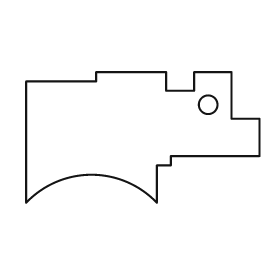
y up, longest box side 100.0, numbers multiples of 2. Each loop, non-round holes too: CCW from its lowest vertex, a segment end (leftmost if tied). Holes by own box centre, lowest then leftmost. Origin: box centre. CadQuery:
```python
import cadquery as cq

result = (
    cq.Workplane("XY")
    .moveTo(-50.0, -28.0)
    .threePointArc((-22.0, -16.0), (6.0, -28.0))
    .lineTo(6.0, -12.0)
    .lineTo(12.0, -12.0)
    .lineTo(12.0, -8.0)
    .lineTo(50.0, -8.0)
    .lineTo(50.0, 8.0)
    .lineTo(38.0, 8.0)
    .lineTo(38.0, 28.0)
    .lineTo(22.0, 28.0)
    .lineTo(22.0, 20.0)
    .lineTo(10.0, 20.0)
    .lineTo(10.0, 28.0)
    .lineTo(-20.0, 28.0)
    .lineTo(-20.0, 24.0)
    .lineTo(-50.0, 24.0)
    .close()
    .moveTo(28.0, 14.0)
    .circle(4.0)
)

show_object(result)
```